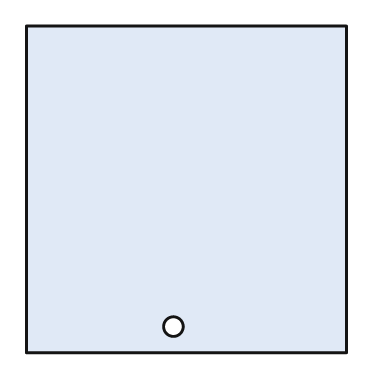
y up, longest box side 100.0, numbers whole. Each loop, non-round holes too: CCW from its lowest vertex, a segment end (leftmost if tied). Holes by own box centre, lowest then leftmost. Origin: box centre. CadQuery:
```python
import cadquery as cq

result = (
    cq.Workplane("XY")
    .moveTo(-49.0, -50.0)
    .lineTo(49.0, -50.0)
    .lineTo(49.0, 50.0)
    .lineTo(-49.0, 50.0)
    .close()
    .moveTo(-4.0, -42.0)
    .circle(3.0)
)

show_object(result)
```